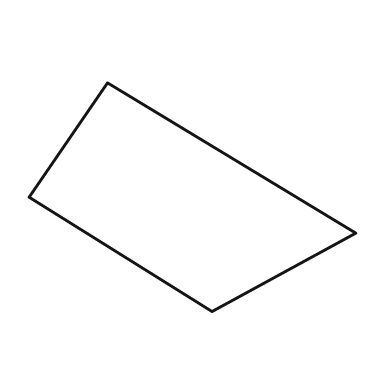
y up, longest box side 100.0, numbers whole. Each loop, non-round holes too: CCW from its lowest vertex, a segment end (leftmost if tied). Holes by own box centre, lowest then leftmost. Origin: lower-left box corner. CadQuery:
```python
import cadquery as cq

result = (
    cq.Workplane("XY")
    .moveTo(56.0, 0.0)
    .lineTo(100.0, 24.0)
    .lineTo(24.0, 70.0)
    .lineTo(0.0, 35.0)
    .close()
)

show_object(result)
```